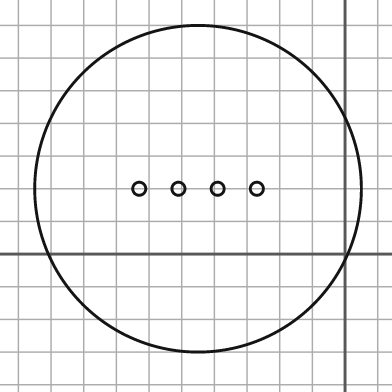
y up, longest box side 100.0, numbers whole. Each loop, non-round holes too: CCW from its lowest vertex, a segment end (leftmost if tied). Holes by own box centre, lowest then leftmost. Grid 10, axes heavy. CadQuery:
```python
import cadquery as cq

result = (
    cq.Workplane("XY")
    .moveTo(-45.0, 20.0)
    .circle(50.0)
    .moveTo(-63.0, 20.0)
    .circle(2.0)
    .moveTo(-51.0, 20.0)
    .circle(2.0)
    .moveTo(-39.0, 20.0)
    .circle(2.0)
    .moveTo(-27.0, 20.0)
    .circle(2.0)
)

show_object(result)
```